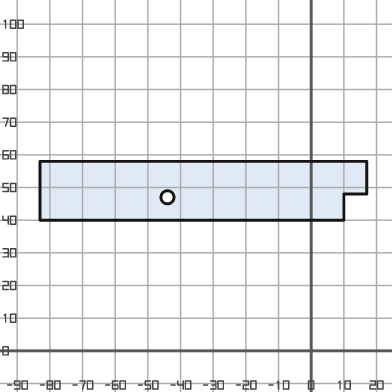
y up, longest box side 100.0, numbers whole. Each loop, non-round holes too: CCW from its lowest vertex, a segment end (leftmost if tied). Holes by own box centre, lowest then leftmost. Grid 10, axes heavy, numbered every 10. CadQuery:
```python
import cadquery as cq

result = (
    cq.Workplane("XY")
    .moveTo(-83.0, 40.0)
    .lineTo(10.0, 40.0)
    .lineTo(10.0, 48.0)
    .lineTo(17.0, 48.0)
    .lineTo(17.0, 58.0)
    .lineTo(-83.0, 58.0)
    .close()
    .moveTo(-44.0, 47.0)
    .circle(2.0)
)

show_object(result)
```